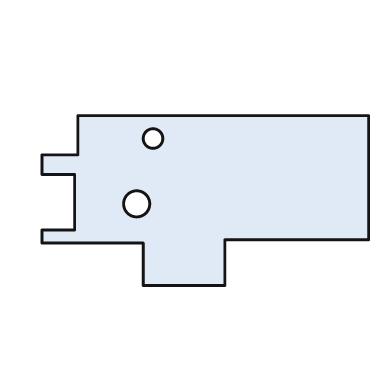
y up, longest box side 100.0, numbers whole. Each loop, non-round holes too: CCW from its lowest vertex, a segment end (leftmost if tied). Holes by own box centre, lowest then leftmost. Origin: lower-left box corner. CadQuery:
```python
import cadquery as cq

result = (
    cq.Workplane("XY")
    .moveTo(31.0, 0.0)
    .lineTo(56.0, 0.0)
    .lineTo(56.0, 14.0)
    .lineTo(100.0, 14.0)
    .lineTo(100.0, 52.0)
    .lineTo(11.0, 52.0)
    .lineTo(11.0, 40.0)
    .lineTo(0.0, 40.0)
    .lineTo(0.0, 34.0)
    .lineTo(10.0, 34.0)
    .lineTo(10.0, 17.0)
    .lineTo(0.0, 17.0)
    .lineTo(0.0, 13.0)
    .lineTo(31.0, 13.0)
    .close()
    .moveTo(29.0, 25.0)
    .circle(4.0)
    .moveTo(34.0, 45.0)
    .circle(3.0)
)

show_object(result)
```